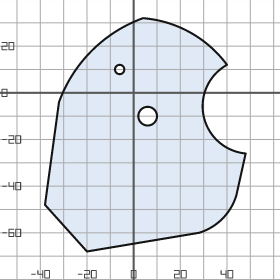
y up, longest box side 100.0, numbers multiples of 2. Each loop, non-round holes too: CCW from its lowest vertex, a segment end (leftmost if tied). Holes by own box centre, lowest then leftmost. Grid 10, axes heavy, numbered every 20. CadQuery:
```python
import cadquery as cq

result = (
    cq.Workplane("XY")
    .moveTo(-20.0, -68.0)
    .lineTo(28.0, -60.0)
    .threePointArc((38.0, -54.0), (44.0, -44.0))
    .lineTo(48.0, -26.0)
    .threePointArc((30.0, -10.0), (40.0, 12.0))
    .threePointArc((24.0, 26.0), (4.0, 32.0))
    .threePointArc((-18.0, 18.0), (-32.0, -4.0))
    .lineTo(-38.0, -48.0)
    .close()
    .moveTo(6.0, -10.0)
    .circle(4.0)
    .moveTo(-6.0, 10.0)
    .circle(2.0)
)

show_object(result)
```